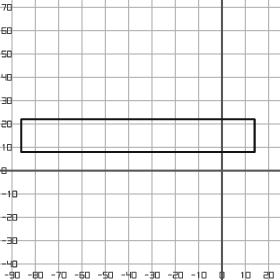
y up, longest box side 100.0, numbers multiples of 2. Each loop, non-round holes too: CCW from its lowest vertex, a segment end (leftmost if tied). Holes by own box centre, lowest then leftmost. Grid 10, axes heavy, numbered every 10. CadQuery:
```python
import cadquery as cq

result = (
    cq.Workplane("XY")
    .moveTo(-86.0, 8.0)
    .lineTo(14.0, 8.0)
    .lineTo(14.0, 22.0)
    .lineTo(-86.0, 22.0)
    .close()
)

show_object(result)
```